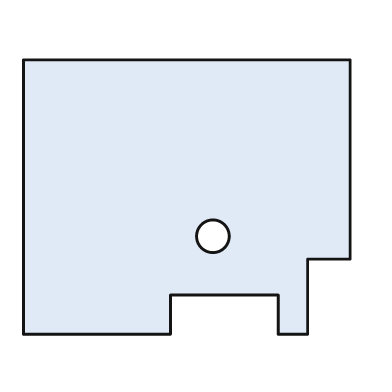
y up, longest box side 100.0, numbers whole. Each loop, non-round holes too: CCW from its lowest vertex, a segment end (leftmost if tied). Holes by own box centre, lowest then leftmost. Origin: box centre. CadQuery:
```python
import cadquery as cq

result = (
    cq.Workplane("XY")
    .moveTo(-50.0, -42.0)
    .lineTo(-5.0, -42.0)
    .lineTo(-5.0, -30.0)
    .lineTo(28.0, -30.0)
    .lineTo(28.0, -42.0)
    .lineTo(37.0, -42.0)
    .lineTo(37.0, -19.0)
    .lineTo(50.0, -19.0)
    .lineTo(50.0, 42.0)
    .lineTo(-50.0, 42.0)
    .close()
    .moveTo(8.0, -12.0)
    .circle(5.0)
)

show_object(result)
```